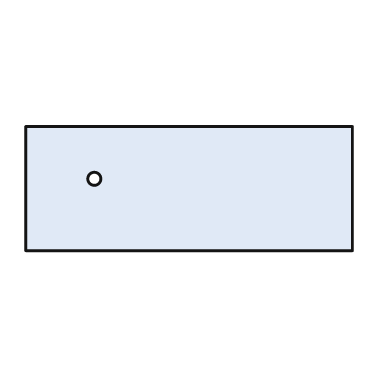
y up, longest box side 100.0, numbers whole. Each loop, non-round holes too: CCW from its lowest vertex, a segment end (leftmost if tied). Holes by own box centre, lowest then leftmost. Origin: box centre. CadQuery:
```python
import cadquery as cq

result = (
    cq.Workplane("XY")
    .moveTo(-50.0, -19.0)
    .lineTo(50.0, -19.0)
    .lineTo(50.0, 19.0)
    .lineTo(-50.0, 19.0)
    .close()
    .moveTo(-29.0, 3.0)
    .circle(2.0)
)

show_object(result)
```